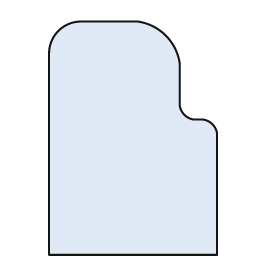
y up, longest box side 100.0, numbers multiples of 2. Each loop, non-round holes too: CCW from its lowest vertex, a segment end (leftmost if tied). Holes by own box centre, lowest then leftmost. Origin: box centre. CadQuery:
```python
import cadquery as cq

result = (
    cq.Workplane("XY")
    .moveTo(-36.0, -50.0)
    .lineTo(36.0, -50.0)
    .lineTo(36.0, 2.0)
    .threePointArc((34.0, 6.0), (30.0, 8.0))
    .lineTo(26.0, 8.0)
    .threePointArc((22.0, 10.0), (20.0, 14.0))
    .lineTo(20.0, 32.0)
    .threePointArc((14.0, 44.0), (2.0, 50.0))
    .lineTo(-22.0, 50.0)
    .threePointArc((-32.0, 46.0), (-36.0, 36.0))
    .close()
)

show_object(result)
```